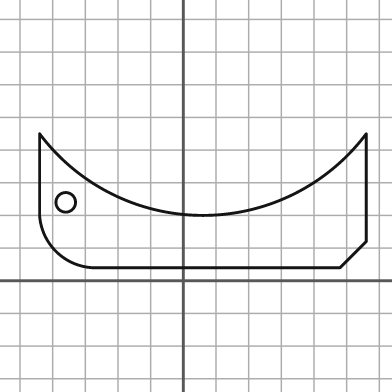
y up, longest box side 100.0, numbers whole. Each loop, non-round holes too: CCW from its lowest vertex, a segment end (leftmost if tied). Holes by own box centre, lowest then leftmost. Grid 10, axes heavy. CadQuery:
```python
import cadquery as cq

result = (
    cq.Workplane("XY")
    .moveTo(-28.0, 4.0)
    .lineTo(48.0, 4.0)
    .lineTo(56.0, 12.0)
    .lineTo(56.0, 45.0)
    .threePointArc((6.0, 20.0), (-44.0, 45.0))
    .lineTo(-44.0, 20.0)
    .threePointArc((-39.0, 9.0), (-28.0, 4.0))
    .close()
    .moveTo(-36.0, 24.0)
    .circle(3.0)
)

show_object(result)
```